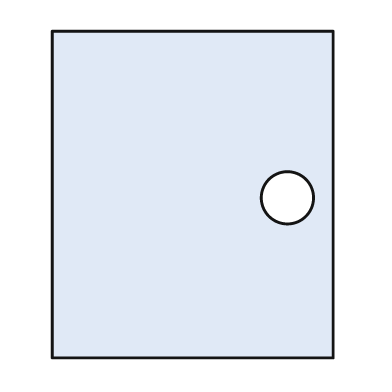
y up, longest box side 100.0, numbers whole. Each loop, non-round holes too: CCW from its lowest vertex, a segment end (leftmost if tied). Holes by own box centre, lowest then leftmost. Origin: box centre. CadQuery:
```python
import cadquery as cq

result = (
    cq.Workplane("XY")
    .moveTo(-43.0, -50.0)
    .lineTo(43.0, -50.0)
    .lineTo(43.0, 50.0)
    .lineTo(-43.0, 50.0)
    .close()
    .moveTo(29.0, -1.0)
    .circle(8.0)
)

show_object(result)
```